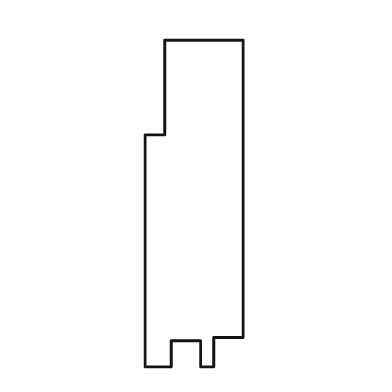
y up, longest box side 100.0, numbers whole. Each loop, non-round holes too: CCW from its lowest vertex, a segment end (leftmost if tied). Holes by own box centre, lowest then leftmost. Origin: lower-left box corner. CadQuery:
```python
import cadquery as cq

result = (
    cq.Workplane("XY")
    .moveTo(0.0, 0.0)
    .lineTo(8.0, 0.0)
    .lineTo(8.0, 8.0)
    .lineTo(17.0, 8.0)
    .lineTo(17.0, 0.0)
    .lineTo(21.0, 0.0)
    .lineTo(21.0, 9.0)
    .lineTo(30.0, 9.0)
    .lineTo(30.0, 100.0)
    .lineTo(6.0, 100.0)
    .lineTo(6.0, 71.0)
    .lineTo(0.0, 71.0)
    .close()
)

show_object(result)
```